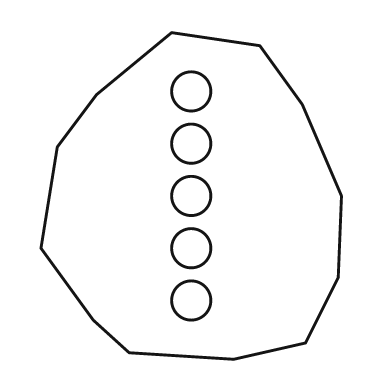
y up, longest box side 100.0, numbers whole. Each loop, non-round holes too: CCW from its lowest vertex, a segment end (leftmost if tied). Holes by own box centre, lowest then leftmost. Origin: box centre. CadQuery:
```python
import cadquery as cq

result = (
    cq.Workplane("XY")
    .moveTo(13.0, -50.0)
    .lineTo(35.0, -45.0)
    .lineTo(45.0, -25.0)
    .lineTo(46.0, 0.0)
    .lineTo(34.0, 28.0)
    .lineTo(21.0, 46.0)
    .lineTo(-6.0, 50.0)
    .lineTo(-29.0, 31.0)
    .lineTo(-41.0, 15.0)
    .lineTo(-46.0, -16.0)
    .lineTo(-30.0, -38.0)
    .lineTo(-19.0, -48.0)
    .close()
    .moveTo(0.0, -32.0)
    .circle(6.0)
    .moveTo(0.0, -16.0)
    .circle(6.0)
    .moveTo(0.0, 0.0)
    .circle(6.0)
    .moveTo(0.0, 16.0)
    .circle(6.0)
    .moveTo(0.0, 32.0)
    .circle(6.0)
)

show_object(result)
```